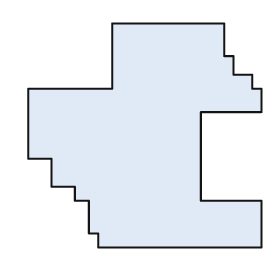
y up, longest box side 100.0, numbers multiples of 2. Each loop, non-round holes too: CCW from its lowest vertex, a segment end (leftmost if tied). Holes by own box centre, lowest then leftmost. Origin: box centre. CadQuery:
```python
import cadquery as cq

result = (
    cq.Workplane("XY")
    .moveTo(-20.0, -48.0)
    .lineTo(50.0, -48.0)
    .lineTo(50.0, -28.0)
    .lineTo(24.0, -28.0)
    .lineTo(24.0, 10.0)
    .lineTo(50.0, 10.0)
    .lineTo(50.0, 20.0)
    .lineTo(46.0, 20.0)
    .lineTo(46.0, 26.0)
    .lineTo(38.0, 26.0)
    .lineTo(38.0, 34.0)
    .lineTo(34.0, 34.0)
    .lineTo(34.0, 48.0)
    .lineTo(-14.0, 48.0)
    .lineTo(-14.0, 20.0)
    .lineTo(-50.0, 20.0)
    .lineTo(-50.0, -10.0)
    .lineTo(-40.0, -10.0)
    .lineTo(-40.0, -22.0)
    .lineTo(-30.0, -22.0)
    .lineTo(-30.0, -28.0)
    .lineTo(-24.0, -28.0)
    .lineTo(-24.0, -42.0)
    .lineTo(-20.0, -42.0)
    .close()
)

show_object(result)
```